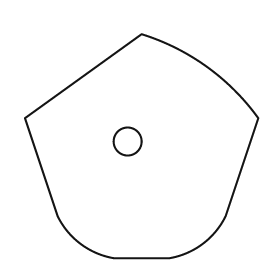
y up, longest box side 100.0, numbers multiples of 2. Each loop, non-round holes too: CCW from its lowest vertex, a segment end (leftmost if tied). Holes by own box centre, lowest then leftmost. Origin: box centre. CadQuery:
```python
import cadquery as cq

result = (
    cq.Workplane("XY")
    .moveTo(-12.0, -48.0)
    .lineTo(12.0, -48.0)
    .threePointArc((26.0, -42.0), (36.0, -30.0))
    .lineTo(50.0, 12.0)
    .threePointArc((28.0, 34.0), (0.0, 48.0))
    .lineTo(-50.0, 12.0)
    .lineTo(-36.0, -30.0)
    .threePointArc((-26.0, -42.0), (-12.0, -48.0))
    .close()
    .moveTo(-6.0, 2.0)
    .circle(6.0)
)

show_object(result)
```